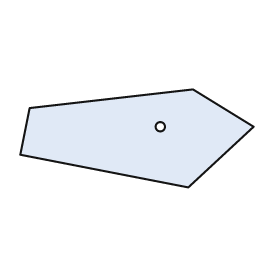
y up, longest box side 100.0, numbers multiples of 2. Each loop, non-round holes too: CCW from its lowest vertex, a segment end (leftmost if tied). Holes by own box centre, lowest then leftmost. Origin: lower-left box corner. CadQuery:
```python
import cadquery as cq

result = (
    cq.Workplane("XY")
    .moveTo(72.0, 0.0)
    .lineTo(100.0, 26.0)
    .lineTo(74.0, 42.0)
    .lineTo(4.0, 34.0)
    .lineTo(0.0, 14.0)
    .close()
    .moveTo(60.0, 26.0)
    .circle(2.0)
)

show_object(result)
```